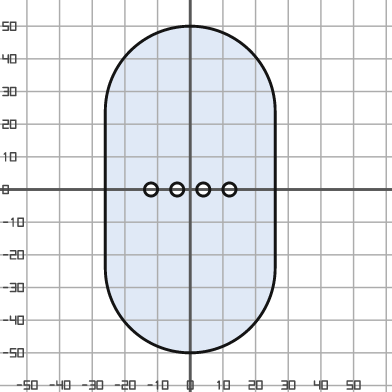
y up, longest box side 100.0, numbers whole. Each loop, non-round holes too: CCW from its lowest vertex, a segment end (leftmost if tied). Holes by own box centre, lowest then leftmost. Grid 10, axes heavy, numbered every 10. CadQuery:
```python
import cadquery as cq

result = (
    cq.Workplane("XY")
    .moveTo(-26.0, -24.0)
    .threePointArc((0.0, -50.0), (26.0, -24.0))
    .lineTo(26.0, 24.0)
    .threePointArc((0.0, 50.0), (-26.0, 24.0))
    .close()
    .moveTo(-12.0, 0.0)
    .circle(2.0)
    .moveTo(-4.0, 0.0)
    .circle(2.0)
    .moveTo(4.0, 0.0)
    .circle(2.0)
    .moveTo(12.0, 0.0)
    .circle(2.0)
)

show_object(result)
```